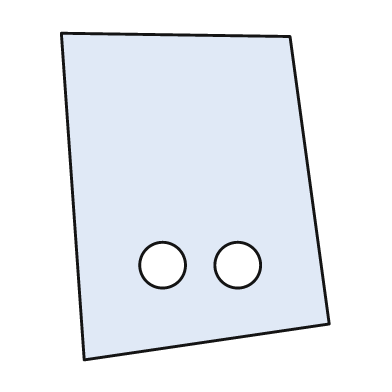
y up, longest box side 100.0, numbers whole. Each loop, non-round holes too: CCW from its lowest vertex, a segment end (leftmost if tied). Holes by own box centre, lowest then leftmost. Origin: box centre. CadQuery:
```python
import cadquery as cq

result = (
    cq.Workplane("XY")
    .moveTo(-34.0, -50.0)
    .lineTo(41.0, -39.0)
    .lineTo(29.0, 49.0)
    .lineTo(-41.0, 50.0)
    .close()
    .moveTo(-10.0, -21.0)
    .circle(7.0)
    .moveTo(13.0, -21.0)
    .circle(7.0)
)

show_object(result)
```